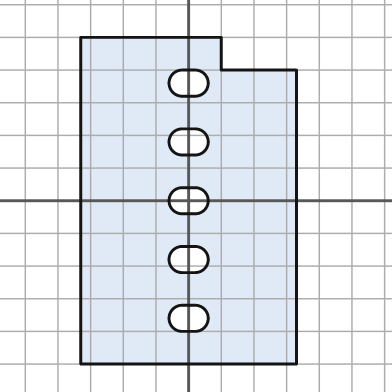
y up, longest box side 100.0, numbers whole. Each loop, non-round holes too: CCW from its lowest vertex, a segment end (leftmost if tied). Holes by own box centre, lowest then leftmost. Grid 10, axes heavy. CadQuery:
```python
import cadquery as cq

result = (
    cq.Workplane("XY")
    .moveTo(-33.0, -50.0)
    .lineTo(33.0, -50.0)
    .lineTo(33.0, 40.0)
    .lineTo(10.0, 40.0)
    .lineTo(10.0, 50.0)
    .lineTo(-33.0, 50.0)
    .close()
    .moveTo(-2.0, -40.0)
    .lineTo(2.0, -40.0)
    .threePointArc((6.0, -36.0), (2.0, -32.0))
    .lineTo(-2.0, -32.0)
    .threePointArc((-6.0, -36.0), (-2.0, -40.0))
    .close()
    .moveTo(-2.0, -22.0)
    .lineTo(2.0, -22.0)
    .threePointArc((6.0, -18.0), (2.0, -14.0))
    .lineTo(-2.0, -14.0)
    .threePointArc((-6.0, -18.0), (-2.0, -22.0))
    .close()
    .moveTo(-2.0, -4.0)
    .lineTo(2.0, -4.0)
    .threePointArc((6.0, 0.0), (2.0, 4.0))
    .lineTo(-2.0, 4.0)
    .threePointArc((-6.0, 0.0), (-2.0, -4.0))
    .close()
    .moveTo(-2.0, 14.0)
    .lineTo(2.0, 14.0)
    .threePointArc((6.0, 18.0), (2.0, 22.0))
    .lineTo(-2.0, 22.0)
    .threePointArc((-6.0, 18.0), (-2.0, 14.0))
    .close()
    .moveTo(-2.0, 32.0)
    .lineTo(2.0, 32.0)
    .threePointArc((6.0, 36.0), (2.0, 40.0))
    .lineTo(-2.0, 40.0)
    .threePointArc((-6.0, 36.0), (-2.0, 32.0))
    .close()
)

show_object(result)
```